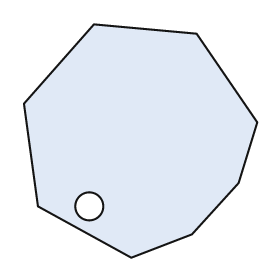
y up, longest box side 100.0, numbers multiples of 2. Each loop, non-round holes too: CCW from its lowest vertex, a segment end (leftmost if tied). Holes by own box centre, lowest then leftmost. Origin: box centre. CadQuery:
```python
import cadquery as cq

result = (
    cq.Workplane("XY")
    .moveTo(-4.0, -50.0)
    .lineTo(22.0, -40.0)
    .lineTo(42.0, -18.0)
    .lineTo(50.0, 8.0)
    .lineTo(24.0, 46.0)
    .lineTo(-20.0, 50.0)
    .lineTo(-50.0, 16.0)
    .lineTo(-44.0, -28.0)
    .close()
    .moveTo(-22.0, -28.0)
    .circle(6.0)
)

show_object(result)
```